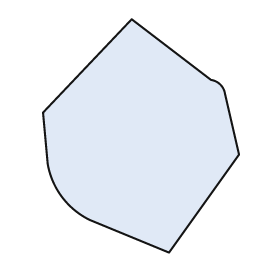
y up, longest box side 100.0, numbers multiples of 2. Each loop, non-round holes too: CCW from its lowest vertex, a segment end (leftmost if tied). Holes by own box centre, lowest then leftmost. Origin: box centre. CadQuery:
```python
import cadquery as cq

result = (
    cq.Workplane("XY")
    .moveTo(12.0, -50.0)
    .lineTo(42.0, -8.0)
    .lineTo(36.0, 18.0)
    .threePointArc((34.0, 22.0), (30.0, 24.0))
    .lineTo(-4.0, 50.0)
    .lineTo(-42.0, 10.0)
    .lineTo(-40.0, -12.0)
    .threePointArc((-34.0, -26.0), (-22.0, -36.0))
    .close()
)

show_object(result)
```